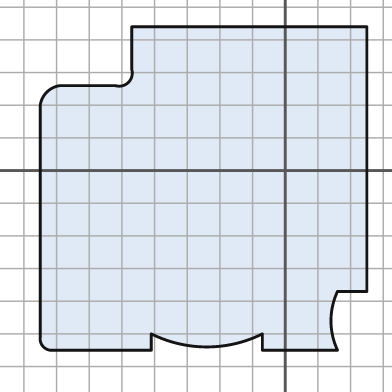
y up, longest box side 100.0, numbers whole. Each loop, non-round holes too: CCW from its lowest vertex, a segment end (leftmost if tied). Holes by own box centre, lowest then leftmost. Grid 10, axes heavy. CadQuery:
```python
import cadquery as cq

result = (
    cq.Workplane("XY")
    .moveTo(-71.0, -55.0)
    .lineTo(-41.0, -55.0)
    .lineTo(-41.0, -50.0)
    .threePointArc((-24.0, -54.0), (-7.0, -50.0))
    .lineTo(-7.0, -55.0)
    .lineTo(16.0, -55.0)
    .threePointArc((14.0, -46.0), (16.0, -37.0))
    .lineTo(25.0, -37.0)
    .lineTo(25.0, 44.0)
    .lineTo(-47.0, 44.0)
    .lineTo(-47.0, 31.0)
    .threePointArc((-48.0, 27.0), (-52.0, 26.0))
    .lineTo(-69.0, 26.0)
    .threePointArc((-73.0, 24.0), (-75.0, 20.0))
    .lineTo(-75.0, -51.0)
    .threePointArc((-74.0, -54.0), (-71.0, -55.0))
    .close()
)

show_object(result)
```